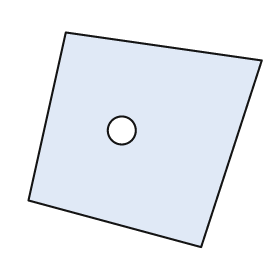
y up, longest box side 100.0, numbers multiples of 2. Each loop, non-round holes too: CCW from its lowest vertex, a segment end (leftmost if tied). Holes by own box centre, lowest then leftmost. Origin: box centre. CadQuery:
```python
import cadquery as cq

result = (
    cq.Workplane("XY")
    .moveTo(24.0, -46.0)
    .lineTo(50.0, 34.0)
    .lineTo(-34.0, 46.0)
    .lineTo(-50.0, -26.0)
    .close()
    .moveTo(-10.0, 4.0)
    .circle(6.0)
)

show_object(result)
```